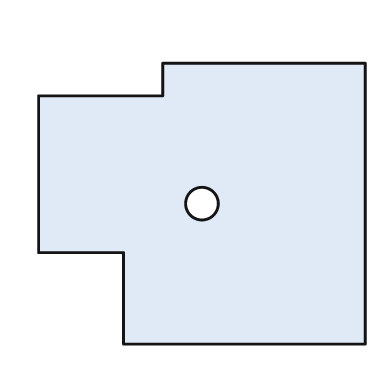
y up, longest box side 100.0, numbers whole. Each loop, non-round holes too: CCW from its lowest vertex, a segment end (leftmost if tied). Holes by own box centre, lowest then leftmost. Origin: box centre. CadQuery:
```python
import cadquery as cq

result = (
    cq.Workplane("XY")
    .moveTo(-24.0, -43.0)
    .lineTo(50.0, -43.0)
    .lineTo(50.0, 43.0)
    .lineTo(-12.0, 43.0)
    .lineTo(-12.0, 33.0)
    .lineTo(-50.0, 33.0)
    .lineTo(-50.0, -15.0)
    .lineTo(-24.0, -15.0)
    .close()
    .moveTo(0.0, 0.0)
    .circle(5.0)
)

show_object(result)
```